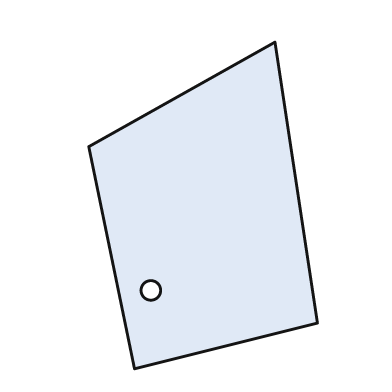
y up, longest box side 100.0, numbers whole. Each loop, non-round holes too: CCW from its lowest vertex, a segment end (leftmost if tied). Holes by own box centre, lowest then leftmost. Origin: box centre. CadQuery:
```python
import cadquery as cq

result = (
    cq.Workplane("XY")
    .moveTo(-21.0, -50.0)
    .lineTo(35.0, -36.0)
    .lineTo(22.0, 50.0)
    .lineTo(-35.0, 18.0)
    .close()
    .moveTo(-16.0, -26.0)
    .circle(3.0)
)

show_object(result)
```